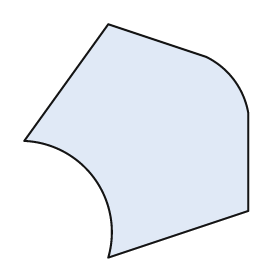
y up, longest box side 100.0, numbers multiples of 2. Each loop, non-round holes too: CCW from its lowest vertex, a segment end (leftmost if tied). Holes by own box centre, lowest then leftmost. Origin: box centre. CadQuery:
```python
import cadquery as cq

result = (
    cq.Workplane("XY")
    .moveTo(-12.0, -50.0)
    .lineTo(48.0, -30.0)
    .lineTo(48.0, 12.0)
    .threePointArc((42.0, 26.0), (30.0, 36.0))
    .lineTo(-12.0, 50.0)
    .lineTo(-48.0, 0.0)
    .threePointArc((-18.0, -16.0), (-12.0, -50.0))
    .close()
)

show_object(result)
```